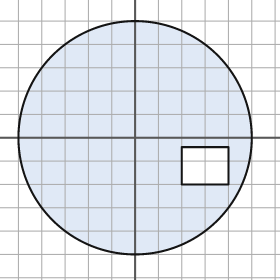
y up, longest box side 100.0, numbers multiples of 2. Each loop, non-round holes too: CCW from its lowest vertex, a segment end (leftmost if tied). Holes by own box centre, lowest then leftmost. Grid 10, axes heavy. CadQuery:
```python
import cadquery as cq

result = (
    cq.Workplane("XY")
    .moveTo(0.0, 0.0)
    .circle(50.0)
    .moveTo(20.0, -20.0)
    .lineTo(40.0, -20.0)
    .lineTo(40.0, -4.0)
    .lineTo(20.0, -4.0)
    .close()
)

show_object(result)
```